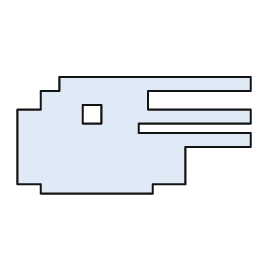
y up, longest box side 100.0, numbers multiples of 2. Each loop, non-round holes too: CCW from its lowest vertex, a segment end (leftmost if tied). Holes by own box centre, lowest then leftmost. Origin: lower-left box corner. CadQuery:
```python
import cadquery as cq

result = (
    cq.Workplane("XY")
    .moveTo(10.0, 0.0)
    .lineTo(58.0, 0.0)
    .lineTo(58.0, 4.0)
    .lineTo(72.0, 4.0)
    .lineTo(72.0, 20.0)
    .lineTo(100.0, 20.0)
    .lineTo(100.0, 26.0)
    .lineTo(52.0, 26.0)
    .lineTo(52.0, 30.0)
    .lineTo(100.0, 30.0)
    .lineTo(100.0, 36.0)
    .lineTo(56.0, 36.0)
    .lineTo(56.0, 44.0)
    .lineTo(100.0, 44.0)
    .lineTo(100.0, 50.0)
    .lineTo(18.0, 50.0)
    .lineTo(18.0, 44.0)
    .lineTo(10.0, 44.0)
    .lineTo(10.0, 36.0)
    .lineTo(0.0, 36.0)
    .lineTo(0.0, 4.0)
    .lineTo(10.0, 4.0)
    .close()
    .moveTo(28.0, 30.0)
    .lineTo(36.0, 30.0)
    .lineTo(36.0, 38.0)
    .lineTo(28.0, 38.0)
    .close()
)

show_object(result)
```